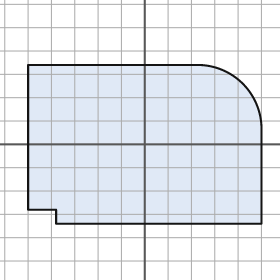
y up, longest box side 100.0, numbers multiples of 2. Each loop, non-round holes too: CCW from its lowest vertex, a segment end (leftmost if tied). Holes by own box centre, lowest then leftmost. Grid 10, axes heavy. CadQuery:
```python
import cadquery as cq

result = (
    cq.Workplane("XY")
    .moveTo(-38.0, -34.0)
    .lineTo(50.0, -34.0)
    .lineTo(50.0, 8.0)
    .threePointArc((42.0, 26.0), (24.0, 34.0))
    .lineTo(-50.0, 34.0)
    .lineTo(-50.0, -28.0)
    .lineTo(-38.0, -28.0)
    .close()
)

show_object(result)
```